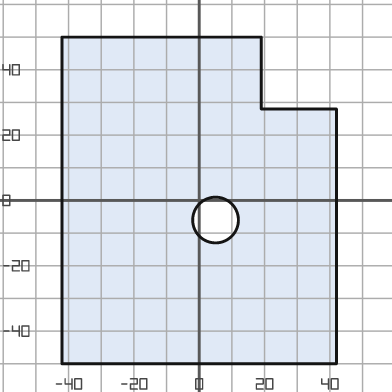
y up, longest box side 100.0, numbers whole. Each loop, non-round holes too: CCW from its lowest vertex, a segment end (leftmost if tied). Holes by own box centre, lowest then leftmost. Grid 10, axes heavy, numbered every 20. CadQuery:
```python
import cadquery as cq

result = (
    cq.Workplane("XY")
    .moveTo(-42.0, -50.0)
    .lineTo(42.0, -50.0)
    .lineTo(42.0, 28.0)
    .lineTo(19.0, 28.0)
    .lineTo(19.0, 50.0)
    .lineTo(-42.0, 50.0)
    .close()
    .moveTo(5.0, -6.0)
    .circle(7.0)
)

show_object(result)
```